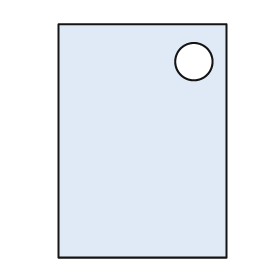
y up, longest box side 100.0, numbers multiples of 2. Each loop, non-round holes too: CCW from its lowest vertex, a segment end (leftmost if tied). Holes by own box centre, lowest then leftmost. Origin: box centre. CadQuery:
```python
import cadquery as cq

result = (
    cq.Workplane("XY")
    .moveTo(-36.0, -50.0)
    .lineTo(36.0, -50.0)
    .lineTo(36.0, 50.0)
    .lineTo(-36.0, 50.0)
    .close()
    .moveTo(22.0, 34.0)
    .circle(8.0)
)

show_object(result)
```